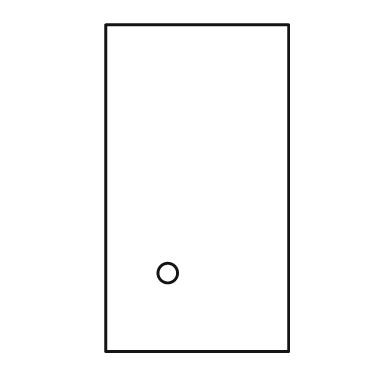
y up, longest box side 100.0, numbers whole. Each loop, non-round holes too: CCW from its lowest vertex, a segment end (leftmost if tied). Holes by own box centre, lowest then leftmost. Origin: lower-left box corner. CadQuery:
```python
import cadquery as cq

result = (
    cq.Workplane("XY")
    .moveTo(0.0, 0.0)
    .lineTo(56.0, 0.0)
    .lineTo(56.0, 100.0)
    .lineTo(0.0, 100.0)
    .close()
    .moveTo(19.0, 24.0)
    .circle(3.0)
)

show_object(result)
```